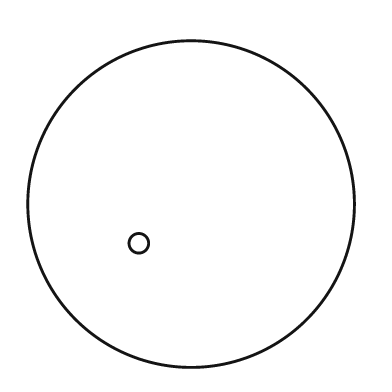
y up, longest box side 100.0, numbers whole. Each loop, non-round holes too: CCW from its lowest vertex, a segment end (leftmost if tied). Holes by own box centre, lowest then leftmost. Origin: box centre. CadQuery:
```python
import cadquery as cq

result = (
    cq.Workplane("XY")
    .moveTo(0.0, 0.0)
    .circle(50.0)
    .moveTo(-16.0, -12.0)
    .circle(3.0)
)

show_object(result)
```